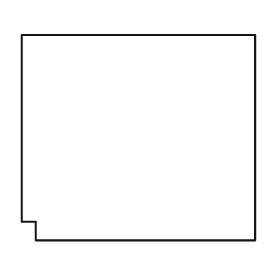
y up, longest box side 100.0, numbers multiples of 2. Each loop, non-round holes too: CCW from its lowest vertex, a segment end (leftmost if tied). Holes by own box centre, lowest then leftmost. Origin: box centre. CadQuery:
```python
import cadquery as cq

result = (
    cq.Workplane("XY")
    .moveTo(-44.0, -44.0)
    .lineTo(50.0, -44.0)
    .lineTo(50.0, 44.0)
    .lineTo(-50.0, 44.0)
    .lineTo(-50.0, -36.0)
    .lineTo(-44.0, -36.0)
    .close()
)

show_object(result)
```